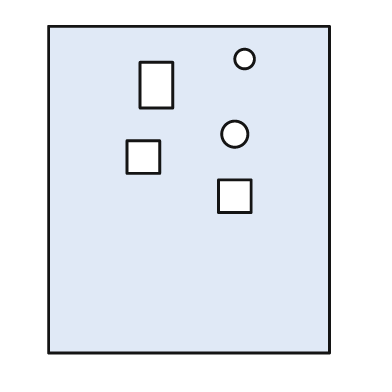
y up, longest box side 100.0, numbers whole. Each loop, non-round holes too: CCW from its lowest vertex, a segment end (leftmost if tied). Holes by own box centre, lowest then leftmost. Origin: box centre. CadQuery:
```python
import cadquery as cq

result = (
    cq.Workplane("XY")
    .moveTo(-43.0, -50.0)
    .lineTo(43.0, -50.0)
    .lineTo(43.0, 50.0)
    .lineTo(-43.0, 50.0)
    .close()
    .moveTo(9.0, -7.0)
    .lineTo(19.0, -7.0)
    .lineTo(19.0, 3.0)
    .lineTo(9.0, 3.0)
    .close()
    .moveTo(-19.0, 5.0)
    .lineTo(-9.0, 5.0)
    .lineTo(-9.0, 15.0)
    .lineTo(-19.0, 15.0)
    .close()
    .moveTo(14.0, 17.0)
    .circle(4.0)
    .moveTo(-15.0, 25.0)
    .lineTo(-5.0, 25.0)
    .lineTo(-5.0, 39.0)
    .lineTo(-15.0, 39.0)
    .close()
    .moveTo(17.0, 40.0)
    .circle(3.0)
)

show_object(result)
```